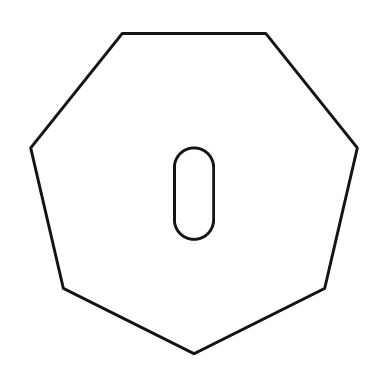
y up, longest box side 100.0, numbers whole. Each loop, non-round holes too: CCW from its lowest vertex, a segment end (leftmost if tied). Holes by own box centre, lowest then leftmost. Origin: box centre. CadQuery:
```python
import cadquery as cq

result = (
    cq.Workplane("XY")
    .moveTo(0.0, -49.0)
    .lineTo(40.0, -29.0)
    .lineTo(50.0, 14.0)
    .lineTo(22.0, 49.0)
    .lineTo(-22.0, 49.0)
    .lineTo(-50.0, 14.0)
    .lineTo(-40.0, -29.0)
    .close()
    .moveTo(-6.0, -8.0)
    .threePointArc((0.0, -14.0), (6.0, -8.0))
    .lineTo(6.0, 8.0)
    .threePointArc((0.0, 14.0), (-6.0, 8.0))
    .close()
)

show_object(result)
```